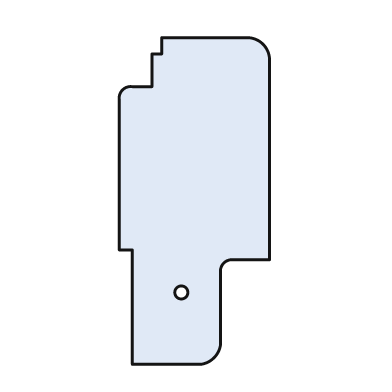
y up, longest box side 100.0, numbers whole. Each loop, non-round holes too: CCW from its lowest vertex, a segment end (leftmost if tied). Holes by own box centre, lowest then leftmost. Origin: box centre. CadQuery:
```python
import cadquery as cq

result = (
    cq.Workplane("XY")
    .moveTo(-19.0, -50.0)
    .lineTo(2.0, -50.0)
    .threePointArc((6.0, -48.0), (8.0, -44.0))
    .lineTo(8.0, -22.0)
    .threePointArc((9.0, -19.0), (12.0, -18.0))
    .lineTo(23.0, -18.0)
    .lineTo(23.0, 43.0)
    .threePointArc((21.0, 48.0), (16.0, 50.0))
    .lineTo(-10.0, 50.0)
    .lineTo(-10.0, 45.0)
    .lineTo(-13.0, 45.0)
    .lineTo(-13.0, 35.0)
    .lineTo(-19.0, 35.0)
    .threePointArc((-22.0, 34.0), (-23.0, 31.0))
    .lineTo(-23.0, -15.0)
    .lineTo(-19.0, -15.0)
    .close()
    .moveTo(-4.0, -28.0)
    .circle(2.0)
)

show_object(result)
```